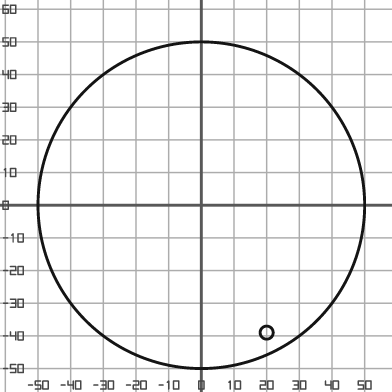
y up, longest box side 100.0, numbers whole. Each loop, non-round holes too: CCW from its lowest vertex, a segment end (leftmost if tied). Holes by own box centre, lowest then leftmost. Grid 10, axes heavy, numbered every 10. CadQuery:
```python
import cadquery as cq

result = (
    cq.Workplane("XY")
    .moveTo(0.0, 0.0)
    .circle(50.0)
    .moveTo(20.0, -39.0)
    .circle(2.0)
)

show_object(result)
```